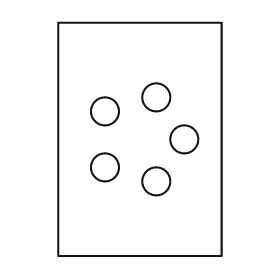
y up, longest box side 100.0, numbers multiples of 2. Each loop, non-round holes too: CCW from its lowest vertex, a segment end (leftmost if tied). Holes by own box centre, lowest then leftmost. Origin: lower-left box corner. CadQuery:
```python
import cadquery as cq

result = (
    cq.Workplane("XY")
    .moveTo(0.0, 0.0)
    .lineTo(70.0, 0.0)
    .lineTo(70.0, 100.0)
    .lineTo(0.0, 100.0)
    .close()
    .moveTo(42.0, 32.0)
    .circle(6.0)
    .moveTo(20.0, 38.0)
    .circle(6.0)
    .moveTo(54.0, 50.0)
    .circle(6.0)
    .moveTo(20.0, 62.0)
    .circle(6.0)
    .moveTo(42.0, 68.0)
    .circle(6.0)
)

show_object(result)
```